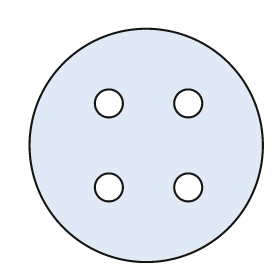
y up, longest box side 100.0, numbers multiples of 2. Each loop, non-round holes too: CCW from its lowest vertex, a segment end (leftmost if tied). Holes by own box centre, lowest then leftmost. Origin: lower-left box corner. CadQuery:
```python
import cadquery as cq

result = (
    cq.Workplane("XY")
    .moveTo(50.0, 50.0)
    .circle(50.0)
    .moveTo(34.0, 32.0)
    .circle(6.0)
    .moveTo(68.0, 32.0)
    .circle(6.0)
    .moveTo(34.0, 68.0)
    .circle(6.0)
    .moveTo(68.0, 68.0)
    .circle(6.0)
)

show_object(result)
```